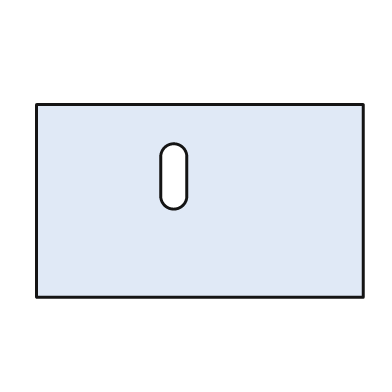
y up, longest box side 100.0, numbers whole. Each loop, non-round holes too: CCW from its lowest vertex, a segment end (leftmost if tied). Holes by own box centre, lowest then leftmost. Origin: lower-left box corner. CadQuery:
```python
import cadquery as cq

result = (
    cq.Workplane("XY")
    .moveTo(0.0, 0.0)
    .lineTo(100.0, 0.0)
    .lineTo(100.0, 59.0)
    .lineTo(0.0, 59.0)
    .close()
    .moveTo(38.0, 31.0)
    .threePointArc((42.0, 27.0), (46.0, 31.0))
    .lineTo(46.0, 43.0)
    .threePointArc((42.0, 47.0), (38.0, 43.0))
    .close()
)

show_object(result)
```